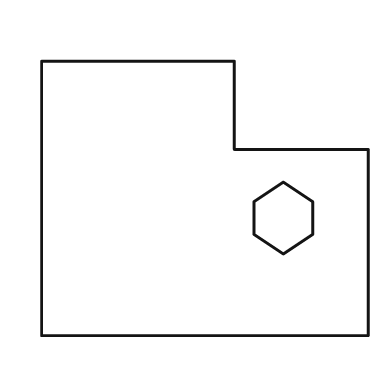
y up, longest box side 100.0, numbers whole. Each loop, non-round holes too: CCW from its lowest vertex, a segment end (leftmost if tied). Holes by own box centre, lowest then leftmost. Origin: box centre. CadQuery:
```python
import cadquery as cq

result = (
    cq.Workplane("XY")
    .moveTo(-50.0, -42.0)
    .lineTo(50.0, -42.0)
    .lineTo(50.0, 15.0)
    .lineTo(9.0, 15.0)
    .lineTo(9.0, 42.0)
    .lineTo(-50.0, 42.0)
    .close()
    .moveTo(24.0, -17.0)
    .lineTo(33.0, -11.0)
    .lineTo(33.0, -1.0)
    .lineTo(24.0, 5.0)
    .lineTo(15.0, -1.0)
    .lineTo(15.0, -11.0)
    .close()
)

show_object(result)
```